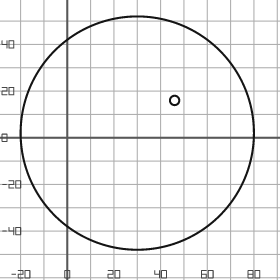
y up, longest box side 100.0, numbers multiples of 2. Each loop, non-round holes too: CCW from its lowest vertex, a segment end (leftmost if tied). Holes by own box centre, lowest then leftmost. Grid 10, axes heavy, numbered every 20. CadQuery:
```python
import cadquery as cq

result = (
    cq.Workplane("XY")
    .moveTo(30.0, 2.0)
    .circle(50.0)
    .moveTo(46.0, 16.0)
    .circle(2.0)
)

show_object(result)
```